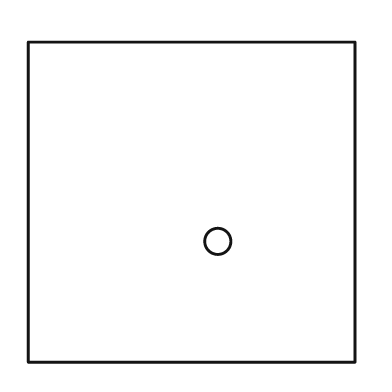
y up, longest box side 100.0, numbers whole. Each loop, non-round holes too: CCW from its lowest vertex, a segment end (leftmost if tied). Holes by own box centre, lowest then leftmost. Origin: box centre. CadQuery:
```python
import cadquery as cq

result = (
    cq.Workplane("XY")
    .moveTo(-50.0, -49.0)
    .lineTo(50.0, -49.0)
    .lineTo(50.0, 49.0)
    .lineTo(-50.0, 49.0)
    .close()
    .moveTo(8.0, -12.0)
    .circle(4.0)
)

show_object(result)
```